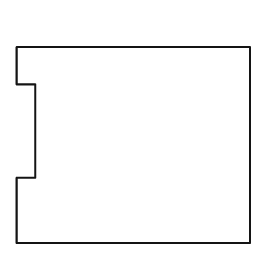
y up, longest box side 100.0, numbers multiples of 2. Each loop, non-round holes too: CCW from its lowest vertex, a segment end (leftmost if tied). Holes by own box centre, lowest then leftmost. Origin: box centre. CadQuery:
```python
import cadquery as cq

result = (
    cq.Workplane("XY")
    .moveTo(-50.0, -42.0)
    .lineTo(50.0, -42.0)
    .lineTo(50.0, 42.0)
    .lineTo(-50.0, 42.0)
    .lineTo(-50.0, 26.0)
    .lineTo(-42.0, 26.0)
    .lineTo(-42.0, -14.0)
    .lineTo(-50.0, -14.0)
    .close()
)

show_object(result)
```